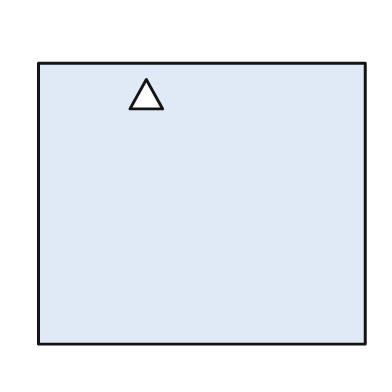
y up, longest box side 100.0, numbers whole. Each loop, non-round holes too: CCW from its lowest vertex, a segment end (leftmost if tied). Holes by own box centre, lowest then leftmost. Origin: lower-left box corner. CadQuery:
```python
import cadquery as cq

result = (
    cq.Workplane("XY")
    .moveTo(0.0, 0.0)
    .lineTo(100.0, 0.0)
    .lineTo(100.0, 86.0)
    .lineTo(0.0, 86.0)
    .close()
    .moveTo(28.0, 72.0)
    .lineTo(38.0, 72.0)
    .lineTo(33.0, 81.0)
    .close()
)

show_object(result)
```